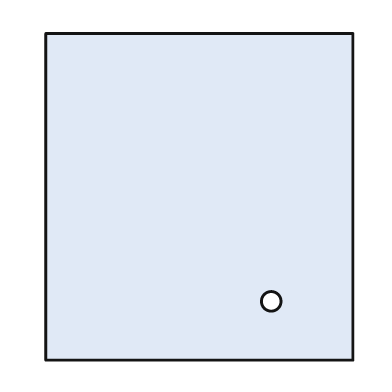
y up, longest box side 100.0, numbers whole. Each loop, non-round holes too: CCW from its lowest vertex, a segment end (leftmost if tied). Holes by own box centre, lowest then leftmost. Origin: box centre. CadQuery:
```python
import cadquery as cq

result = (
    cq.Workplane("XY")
    .moveTo(-47.0, -50.0)
    .lineTo(47.0, -50.0)
    .lineTo(47.0, 50.0)
    .lineTo(-47.0, 50.0)
    .close()
    .moveTo(22.0, -32.0)
    .circle(3.0)
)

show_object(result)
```